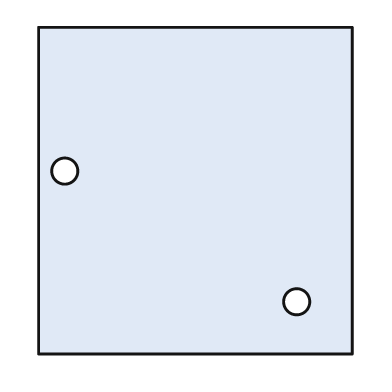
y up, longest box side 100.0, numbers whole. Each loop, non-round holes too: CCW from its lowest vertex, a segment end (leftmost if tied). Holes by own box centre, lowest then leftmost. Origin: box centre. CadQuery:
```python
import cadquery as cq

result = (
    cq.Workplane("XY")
    .moveTo(-48.0, -50.0)
    .lineTo(48.0, -50.0)
    .lineTo(48.0, 50.0)
    .lineTo(-48.0, 50.0)
    .close()
    .moveTo(31.0, -34.0)
    .circle(4.0)
    .moveTo(-40.0, 6.0)
    .circle(4.0)
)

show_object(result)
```